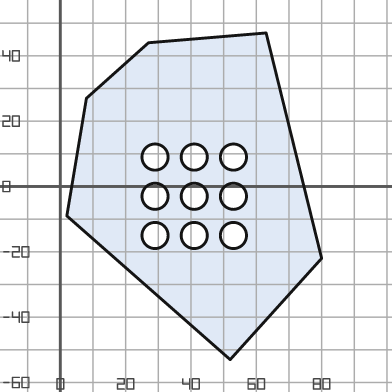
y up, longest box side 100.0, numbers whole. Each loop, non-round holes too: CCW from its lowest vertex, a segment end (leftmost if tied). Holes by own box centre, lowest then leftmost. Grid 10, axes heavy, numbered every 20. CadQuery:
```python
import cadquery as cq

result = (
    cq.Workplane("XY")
    .moveTo(52.0, -53.0)
    .lineTo(80.0, -22.0)
    .lineTo(63.0, 47.0)
    .lineTo(27.0, 44.0)
    .lineTo(8.0, 27.0)
    .lineTo(2.0, -9.0)
    .close()
    .moveTo(29.0, -15.0)
    .circle(4.0)
    .moveTo(41.0, -15.0)
    .circle(4.0)
    .moveTo(53.0, -15.0)
    .circle(4.0)
    .moveTo(29.0, -3.0)
    .circle(4.0)
    .moveTo(41.0, -3.0)
    .circle(4.0)
    .moveTo(53.0, -3.0)
    .circle(4.0)
    .moveTo(29.0, 9.0)
    .circle(4.0)
    .moveTo(41.0, 9.0)
    .circle(4.0)
    .moveTo(53.0, 9.0)
    .circle(4.0)
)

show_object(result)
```